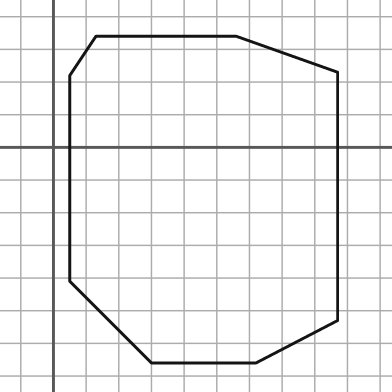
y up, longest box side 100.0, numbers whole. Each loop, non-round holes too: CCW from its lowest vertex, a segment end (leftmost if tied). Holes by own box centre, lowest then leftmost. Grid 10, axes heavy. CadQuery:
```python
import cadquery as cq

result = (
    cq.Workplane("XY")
    .moveTo(30.0, -66.0)
    .lineTo(62.0, -66.0)
    .lineTo(87.0, -53.0)
    .lineTo(87.0, 23.0)
    .lineTo(56.0, 34.0)
    .lineTo(13.0, 34.0)
    .lineTo(5.0, 22.0)
    .lineTo(5.0, -41.0)
    .close()
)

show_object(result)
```